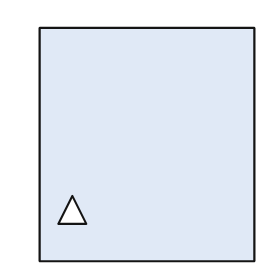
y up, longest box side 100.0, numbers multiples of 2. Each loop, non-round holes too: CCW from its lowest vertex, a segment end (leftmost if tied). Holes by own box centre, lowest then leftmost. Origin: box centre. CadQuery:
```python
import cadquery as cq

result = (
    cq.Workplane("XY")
    .moveTo(-46.0, -50.0)
    .lineTo(46.0, -50.0)
    .lineTo(46.0, 50.0)
    .lineTo(-46.0, 50.0)
    .close()
    .moveTo(-38.0, -34.0)
    .lineTo(-26.0, -34.0)
    .lineTo(-32.0, -22.0)
    .close()
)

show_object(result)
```